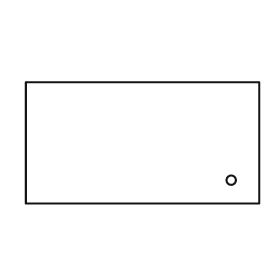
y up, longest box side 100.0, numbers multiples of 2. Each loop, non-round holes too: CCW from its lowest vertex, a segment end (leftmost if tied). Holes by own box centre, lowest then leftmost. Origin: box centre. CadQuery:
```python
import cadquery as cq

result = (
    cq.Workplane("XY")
    .moveTo(-50.0, -26.0)
    .lineTo(50.0, -26.0)
    .lineTo(50.0, 26.0)
    .lineTo(-50.0, 26.0)
    .close()
    .moveTo(38.0, -16.0)
    .circle(2.0)
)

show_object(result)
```